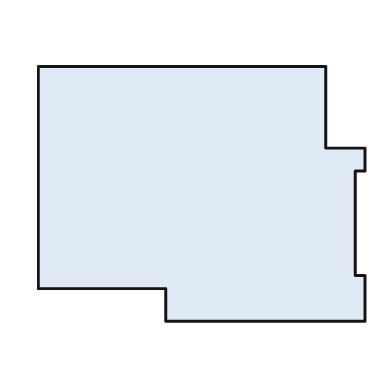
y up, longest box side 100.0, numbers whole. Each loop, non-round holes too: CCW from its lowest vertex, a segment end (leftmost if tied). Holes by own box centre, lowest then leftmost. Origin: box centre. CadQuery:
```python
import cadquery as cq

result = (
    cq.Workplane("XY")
    .moveTo(-11.0, -39.0)
    .lineTo(50.0, -39.0)
    .lineTo(50.0, -25.0)
    .lineTo(47.0, -25.0)
    .lineTo(47.0, 7.0)
    .lineTo(50.0, 7.0)
    .lineTo(50.0, 14.0)
    .lineTo(38.0, 14.0)
    .lineTo(38.0, 39.0)
    .lineTo(-50.0, 39.0)
    .lineTo(-50.0, -29.0)
    .lineTo(-11.0, -29.0)
    .close()
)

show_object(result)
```